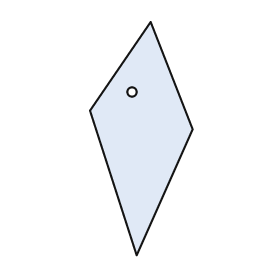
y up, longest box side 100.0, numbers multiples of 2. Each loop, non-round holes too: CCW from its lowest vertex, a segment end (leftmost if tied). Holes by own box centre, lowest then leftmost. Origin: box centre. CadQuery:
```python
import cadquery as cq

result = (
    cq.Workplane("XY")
    .moveTo(-2.0, -50.0)
    .lineTo(22.0, 4.0)
    .lineTo(4.0, 50.0)
    .lineTo(-22.0, 12.0)
    .close()
    .moveTo(-4.0, 20.0)
    .circle(2.0)
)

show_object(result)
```